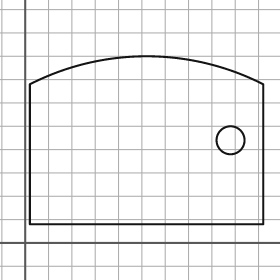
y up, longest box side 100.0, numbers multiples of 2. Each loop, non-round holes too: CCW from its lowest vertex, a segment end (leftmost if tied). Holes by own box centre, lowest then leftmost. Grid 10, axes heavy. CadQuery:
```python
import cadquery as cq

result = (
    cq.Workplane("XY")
    .moveTo(2.0, 8.0)
    .lineTo(102.0, 8.0)
    .lineTo(102.0, 68.0)
    .threePointArc((52.0, 80.0), (2.0, 68.0))
    .close()
    .moveTo(88.0, 44.0)
    .circle(6.0)
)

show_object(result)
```